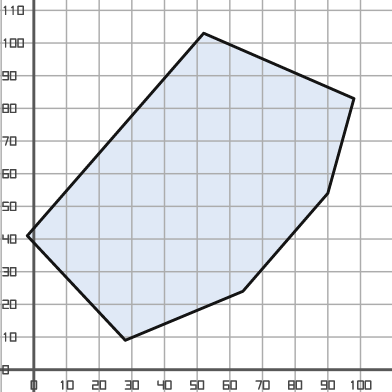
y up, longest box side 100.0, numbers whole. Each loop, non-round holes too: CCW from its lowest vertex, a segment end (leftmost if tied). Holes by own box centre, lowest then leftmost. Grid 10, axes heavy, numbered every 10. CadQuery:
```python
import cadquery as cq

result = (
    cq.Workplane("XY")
    .moveTo(28.0, 9.0)
    .lineTo(64.0, 24.0)
    .lineTo(90.0, 54.0)
    .lineTo(98.0, 83.0)
    .lineTo(52.0, 103.0)
    .lineTo(-2.0, 41.0)
    .close()
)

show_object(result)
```